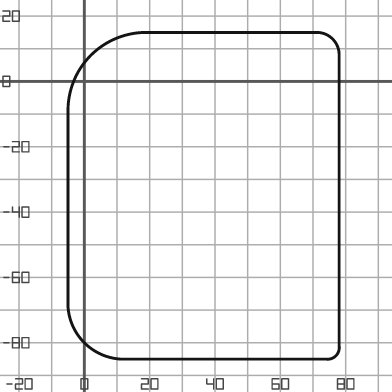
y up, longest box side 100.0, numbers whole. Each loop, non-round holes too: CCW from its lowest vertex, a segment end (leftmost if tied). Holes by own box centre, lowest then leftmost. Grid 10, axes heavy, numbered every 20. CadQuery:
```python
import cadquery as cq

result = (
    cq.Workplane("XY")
    .moveTo(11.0, -85.0)
    .lineTo(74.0, -85.0)
    .threePointArc((77.0, -84.0), (78.0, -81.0))
    .lineTo(78.0, 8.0)
    .threePointArc((76.0, 13.0), (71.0, 15.0))
    .lineTo(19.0, 15.0)
    .threePointArc((2.0, 8.0), (-5.0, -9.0))
    .lineTo(-5.0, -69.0)
    .threePointArc((0.0, -80.0), (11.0, -85.0))
    .close()
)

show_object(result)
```